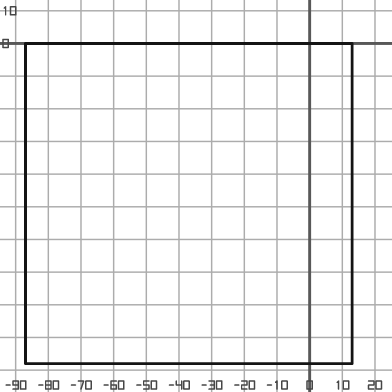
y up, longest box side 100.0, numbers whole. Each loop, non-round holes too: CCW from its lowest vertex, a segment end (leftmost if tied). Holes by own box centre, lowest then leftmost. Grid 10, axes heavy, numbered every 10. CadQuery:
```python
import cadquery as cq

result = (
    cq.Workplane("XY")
    .moveTo(-87.0, -98.0)
    .lineTo(13.0, -98.0)
    .lineTo(13.0, 0.0)
    .lineTo(-87.0, 0.0)
    .close()
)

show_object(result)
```